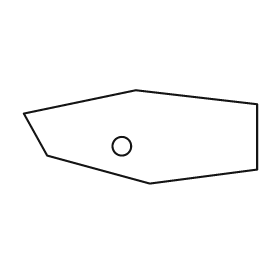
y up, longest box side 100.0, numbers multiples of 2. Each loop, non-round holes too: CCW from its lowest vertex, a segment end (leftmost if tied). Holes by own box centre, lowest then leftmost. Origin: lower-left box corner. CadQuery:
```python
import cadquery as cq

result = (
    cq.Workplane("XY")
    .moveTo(54.0, 0.0)
    .lineTo(100.0, 6.0)
    .lineTo(100.0, 34.0)
    .lineTo(48.0, 40.0)
    .lineTo(0.0, 30.0)
    .lineTo(10.0, 12.0)
    .close()
    .moveTo(42.0, 16.0)
    .circle(4.0)
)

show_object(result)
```